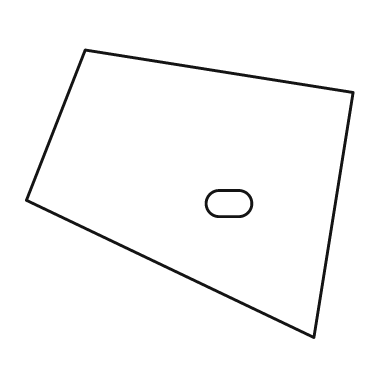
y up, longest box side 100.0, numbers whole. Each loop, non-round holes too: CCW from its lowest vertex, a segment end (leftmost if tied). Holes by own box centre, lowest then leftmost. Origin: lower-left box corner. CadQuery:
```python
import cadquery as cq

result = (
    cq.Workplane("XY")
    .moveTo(88.0, 0.0)
    .lineTo(100.0, 75.0)
    .lineTo(18.0, 88.0)
    .lineTo(0.0, 42.0)
    .close()
    .moveTo(59.0, 37.0)
    .lineTo(65.0, 37.0)
    .threePointArc((69.0, 41.0), (65.0, 45.0))
    .lineTo(59.0, 45.0)
    .threePointArc((55.0, 41.0), (59.0, 37.0))
    .close()
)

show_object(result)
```